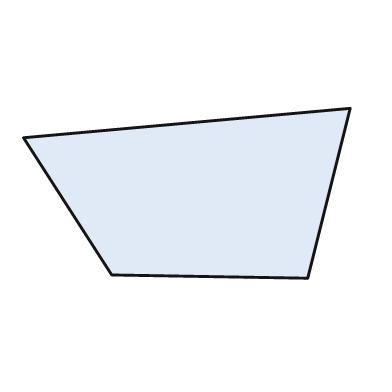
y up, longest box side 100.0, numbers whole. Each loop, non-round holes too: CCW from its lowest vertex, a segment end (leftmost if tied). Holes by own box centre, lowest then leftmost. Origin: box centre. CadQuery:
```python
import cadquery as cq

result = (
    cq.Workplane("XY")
    .moveTo(37.0, -26.0)
    .lineTo(50.0, 26.0)
    .lineTo(-50.0, 17.0)
    .lineTo(-23.0, -25.0)
    .close()
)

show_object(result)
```